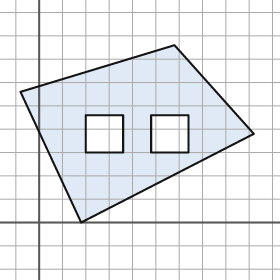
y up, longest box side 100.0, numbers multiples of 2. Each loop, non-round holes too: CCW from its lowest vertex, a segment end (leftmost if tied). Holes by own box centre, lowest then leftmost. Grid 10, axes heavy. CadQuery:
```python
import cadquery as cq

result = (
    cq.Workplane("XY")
    .moveTo(18.0, 0.0)
    .lineTo(92.0, 38.0)
    .lineTo(58.0, 76.0)
    .lineTo(-8.0, 56.0)
    .close()
    .moveTo(20.0, 30.0)
    .lineTo(36.0, 30.0)
    .lineTo(36.0, 46.0)
    .lineTo(20.0, 46.0)
    .close()
    .moveTo(48.0, 30.0)
    .lineTo(64.0, 30.0)
    .lineTo(64.0, 46.0)
    .lineTo(48.0, 46.0)
    .close()
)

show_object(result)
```